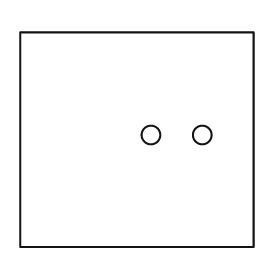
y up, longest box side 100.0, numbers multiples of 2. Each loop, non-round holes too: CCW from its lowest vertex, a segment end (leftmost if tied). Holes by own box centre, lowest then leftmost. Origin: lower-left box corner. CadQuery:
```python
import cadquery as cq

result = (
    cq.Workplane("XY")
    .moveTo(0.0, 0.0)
    .lineTo(100.0, 0.0)
    .lineTo(100.0, 92.0)
    .lineTo(0.0, 92.0)
    .close()
    .moveTo(56.0, 48.0)
    .circle(4.0)
    .moveTo(78.0, 48.0)
    .circle(4.0)
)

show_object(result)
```